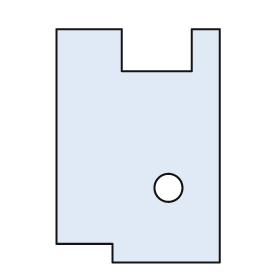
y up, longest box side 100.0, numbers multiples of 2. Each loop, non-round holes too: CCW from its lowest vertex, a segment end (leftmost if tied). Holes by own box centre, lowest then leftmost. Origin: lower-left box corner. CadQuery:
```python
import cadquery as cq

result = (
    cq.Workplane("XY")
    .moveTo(24.0, 0.0)
    .lineTo(70.0, 0.0)
    .lineTo(70.0, 100.0)
    .lineTo(58.0, 100.0)
    .lineTo(58.0, 82.0)
    .lineTo(28.0, 82.0)
    .lineTo(28.0, 100.0)
    .lineTo(0.0, 100.0)
    .lineTo(0.0, 8.0)
    .lineTo(24.0, 8.0)
    .close()
    .moveTo(48.0, 32.0)
    .circle(6.0)
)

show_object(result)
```